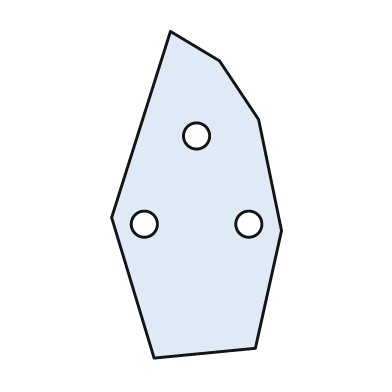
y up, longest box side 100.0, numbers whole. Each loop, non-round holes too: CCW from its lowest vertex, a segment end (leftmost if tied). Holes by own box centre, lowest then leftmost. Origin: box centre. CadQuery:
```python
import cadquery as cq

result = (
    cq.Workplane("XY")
    .moveTo(-13.0, -50.0)
    .lineTo(18.0, -47.0)
    .lineTo(26.0, -11.0)
    .lineTo(19.0, 23.0)
    .lineTo(7.0, 41.0)
    .lineTo(-8.0, 50.0)
    .lineTo(-26.0, -7.0)
    .close()
    .moveTo(-16.0, -9.0)
    .circle(4.0)
    .moveTo(16.0, -9.0)
    .circle(4.0)
    .moveTo(0.0, 18.0)
    .circle(4.0)
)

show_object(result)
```